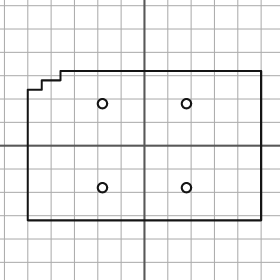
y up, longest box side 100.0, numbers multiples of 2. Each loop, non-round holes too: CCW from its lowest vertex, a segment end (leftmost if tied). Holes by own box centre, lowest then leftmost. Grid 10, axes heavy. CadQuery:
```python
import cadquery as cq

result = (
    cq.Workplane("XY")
    .moveTo(-50.0, -32.0)
    .lineTo(50.0, -32.0)
    .lineTo(50.0, 32.0)
    .lineTo(-36.0, 32.0)
    .lineTo(-36.0, 28.0)
    .lineTo(-44.0, 28.0)
    .lineTo(-44.0, 24.0)
    .lineTo(-50.0, 24.0)
    .close()
    .moveTo(-18.0, -18.0)
    .circle(2.0)
    .moveTo(18.0, -18.0)
    .circle(2.0)
    .moveTo(-18.0, 18.0)
    .circle(2.0)
    .moveTo(18.0, 18.0)
    .circle(2.0)
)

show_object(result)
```